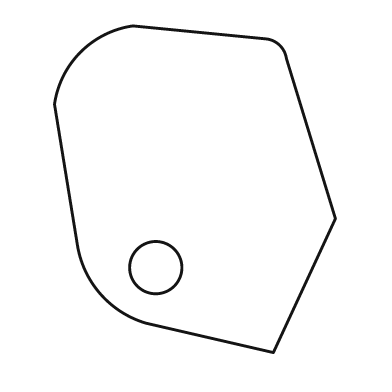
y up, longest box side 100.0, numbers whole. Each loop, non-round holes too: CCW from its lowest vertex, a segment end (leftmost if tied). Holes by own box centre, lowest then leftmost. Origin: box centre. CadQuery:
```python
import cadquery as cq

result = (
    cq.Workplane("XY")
    .moveTo(24.0, -50.0)
    .lineTo(43.0, -9.0)
    .lineTo(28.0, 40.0)
    .threePointArc((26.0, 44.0), (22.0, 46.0))
    .lineTo(-19.0, 50.0)
    .threePointArc((-35.0, 42.0), (-43.0, 26.0))
    .lineTo(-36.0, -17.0)
    .threePointArc((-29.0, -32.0), (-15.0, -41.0))
    .close()
    .moveTo(-12.0, -24.0)
    .circle(8.0)
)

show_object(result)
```